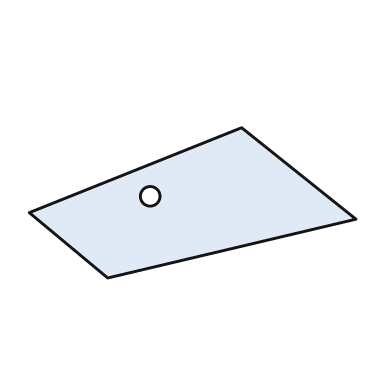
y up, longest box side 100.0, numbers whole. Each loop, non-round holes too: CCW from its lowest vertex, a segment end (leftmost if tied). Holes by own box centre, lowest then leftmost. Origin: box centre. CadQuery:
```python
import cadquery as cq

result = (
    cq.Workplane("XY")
    .moveTo(-26.0, -23.0)
    .lineTo(50.0, -5.0)
    .lineTo(15.0, 23.0)
    .lineTo(-50.0, -3.0)
    .close()
    .moveTo(-13.0, 2.0)
    .circle(3.0)
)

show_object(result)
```